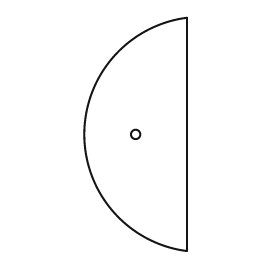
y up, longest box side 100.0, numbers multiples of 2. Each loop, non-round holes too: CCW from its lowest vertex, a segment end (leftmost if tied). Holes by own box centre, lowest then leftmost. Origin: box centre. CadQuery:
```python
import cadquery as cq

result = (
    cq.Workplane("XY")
    .moveTo(22.0, -50.0)
    .lineTo(22.0, 50.0)
    .threePointArc((-22.0, 0.0), (22.0, -50.0))
    .close()
    .moveTo(0.0, 0.0)
    .circle(2.0)
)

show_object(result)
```